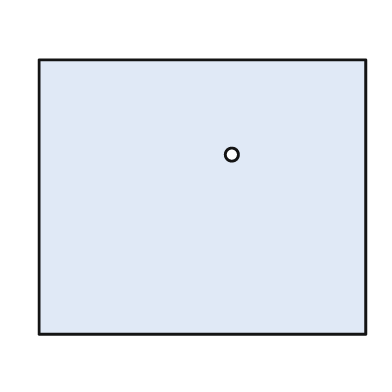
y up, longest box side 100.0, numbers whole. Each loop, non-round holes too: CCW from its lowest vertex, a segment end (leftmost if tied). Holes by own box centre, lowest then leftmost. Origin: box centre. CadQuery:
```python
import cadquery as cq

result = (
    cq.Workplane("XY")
    .moveTo(-50.0, -42.0)
    .lineTo(50.0, -42.0)
    .lineTo(50.0, 42.0)
    .lineTo(-50.0, 42.0)
    .close()
    .moveTo(9.0, 13.0)
    .circle(2.0)
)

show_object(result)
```